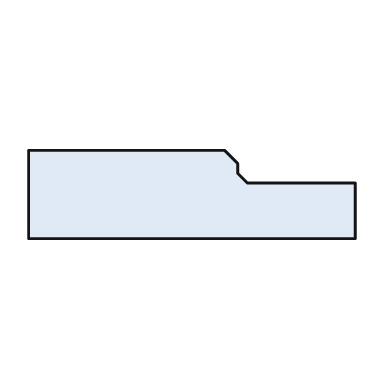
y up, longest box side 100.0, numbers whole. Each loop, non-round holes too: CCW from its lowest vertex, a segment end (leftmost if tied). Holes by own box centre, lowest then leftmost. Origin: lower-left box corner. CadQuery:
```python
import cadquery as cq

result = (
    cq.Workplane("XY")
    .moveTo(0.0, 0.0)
    .lineTo(100.0, 0.0)
    .lineTo(100.0, 17.0)
    .lineTo(67.0, 17.0)
    .lineTo(64.0, 20.0)
    .lineTo(64.0, 23.0)
    .lineTo(60.0, 27.0)
    .lineTo(0.0, 27.0)
    .close()
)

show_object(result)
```